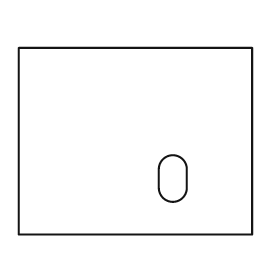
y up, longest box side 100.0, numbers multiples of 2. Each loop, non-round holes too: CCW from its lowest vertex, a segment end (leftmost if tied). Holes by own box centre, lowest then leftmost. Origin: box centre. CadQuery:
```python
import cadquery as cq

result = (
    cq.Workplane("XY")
    .moveTo(-50.0, -40.0)
    .lineTo(50.0, -40.0)
    .lineTo(50.0, 40.0)
    .lineTo(-50.0, 40.0)
    .close()
    .moveTo(10.0, -20.0)
    .threePointArc((16.0, -26.0), (22.0, -20.0))
    .lineTo(22.0, -12.0)
    .threePointArc((16.0, -6.0), (10.0, -12.0))
    .close()
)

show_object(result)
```